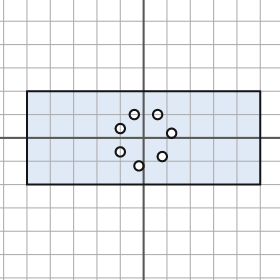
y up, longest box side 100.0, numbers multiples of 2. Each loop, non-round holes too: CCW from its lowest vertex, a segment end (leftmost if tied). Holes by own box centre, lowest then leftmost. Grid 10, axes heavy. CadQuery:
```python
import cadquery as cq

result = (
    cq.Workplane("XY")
    .moveTo(-50.0, -20.0)
    .lineTo(50.0, -20.0)
    .lineTo(50.0, 20.0)
    .lineTo(-50.0, 20.0)
    .close()
    .moveTo(-2.0, -12.0)
    .circle(2.0)
    .moveTo(8.0, -8.0)
    .circle(2.0)
    .moveTo(-10.0, -6.0)
    .circle(2.0)
    .moveTo(12.0, 2.0)
    .circle(2.0)
    .moveTo(-10.0, 4.0)
    .circle(2.0)
    .moveTo(-4.0, 10.0)
    .circle(2.0)
    .moveTo(6.0, 10.0)
    .circle(2.0)
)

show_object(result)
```